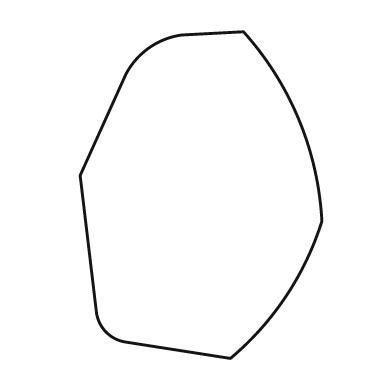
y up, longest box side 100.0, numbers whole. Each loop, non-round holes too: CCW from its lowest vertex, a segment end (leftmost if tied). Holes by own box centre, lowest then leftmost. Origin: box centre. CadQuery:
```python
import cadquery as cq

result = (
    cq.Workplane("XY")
    .moveTo(9.0, -50.0)
    .threePointArc((26.0, -31.0), (37.0, -8.0))
    .threePointArc((30.0, 23.0), (13.0, 50.0))
    .lineTo(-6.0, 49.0)
    .threePointArc((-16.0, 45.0), (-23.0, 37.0))
    .lineTo(-37.0, 6.0)
    .lineTo(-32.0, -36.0)
    .threePointArc((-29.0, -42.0), (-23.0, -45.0))
    .close()
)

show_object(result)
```